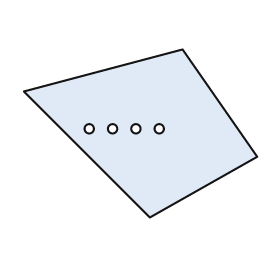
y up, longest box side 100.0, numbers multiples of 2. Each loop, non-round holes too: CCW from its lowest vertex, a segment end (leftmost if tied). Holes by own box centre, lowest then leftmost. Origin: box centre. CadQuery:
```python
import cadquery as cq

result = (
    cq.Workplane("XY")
    .moveTo(4.0, -36.0)
    .lineTo(50.0, -10.0)
    .lineTo(18.0, 36.0)
    .lineTo(-50.0, 18.0)
    .close()
    .moveTo(-22.0, 2.0)
    .circle(2.0)
    .moveTo(-12.0, 2.0)
    .circle(2.0)
    .moveTo(-2.0, 2.0)
    .circle(2.0)
    .moveTo(8.0, 2.0)
    .circle(2.0)
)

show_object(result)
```